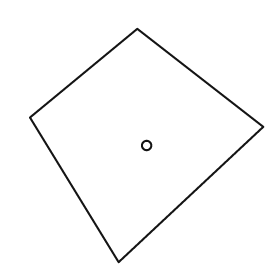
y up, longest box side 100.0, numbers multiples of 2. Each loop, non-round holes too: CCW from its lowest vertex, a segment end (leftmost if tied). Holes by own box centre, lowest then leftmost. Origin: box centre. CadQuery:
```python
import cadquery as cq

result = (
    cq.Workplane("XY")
    .moveTo(-12.0, -50.0)
    .lineTo(50.0, 8.0)
    .lineTo(-4.0, 50.0)
    .lineTo(-50.0, 12.0)
    .close()
    .moveTo(0.0, 0.0)
    .circle(2.0)
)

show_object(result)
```